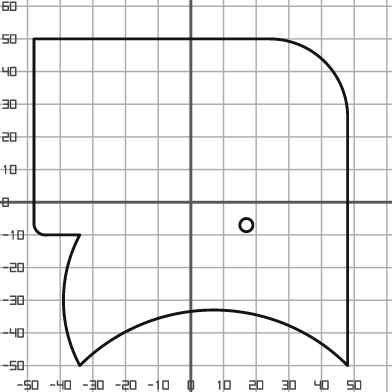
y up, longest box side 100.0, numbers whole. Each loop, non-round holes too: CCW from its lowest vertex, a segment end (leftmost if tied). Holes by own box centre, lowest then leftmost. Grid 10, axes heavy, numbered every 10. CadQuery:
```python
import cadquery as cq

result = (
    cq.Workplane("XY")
    .moveTo(-34.0, -50.0)
    .threePointArc((7.0, -33.0), (48.0, -50.0))
    .lineTo(48.0, 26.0)
    .threePointArc((41.0, 43.0), (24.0, 50.0))
    .lineTo(-48.0, 50.0)
    .lineTo(-48.0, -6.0)
    .threePointArc((-47.0, -9.0), (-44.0, -10.0))
    .lineTo(-34.0, -10.0)
    .threePointArc((-39.0, -30.0), (-34.0, -50.0))
    .close()
    .moveTo(17.0, -7.0)
    .circle(2.0)
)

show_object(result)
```